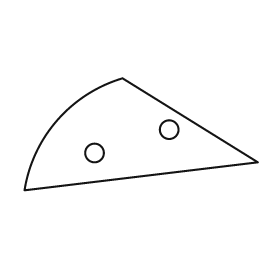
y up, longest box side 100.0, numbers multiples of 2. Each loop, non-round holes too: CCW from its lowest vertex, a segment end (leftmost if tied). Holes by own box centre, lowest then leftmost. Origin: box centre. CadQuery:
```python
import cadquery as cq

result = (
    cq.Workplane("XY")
    .moveTo(-50.0, -24.0)
    .lineTo(50.0, -12.0)
    .lineTo(-8.0, 24.0)
    .threePointArc((-36.0, 6.0), (-50.0, -24.0))
    .close()
    .moveTo(-20.0, -8.0)
    .circle(4.0)
    .moveTo(12.0, 2.0)
    .circle(4.0)
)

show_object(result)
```